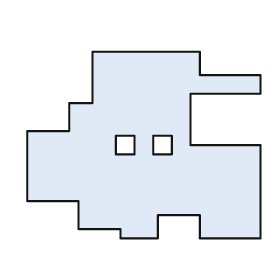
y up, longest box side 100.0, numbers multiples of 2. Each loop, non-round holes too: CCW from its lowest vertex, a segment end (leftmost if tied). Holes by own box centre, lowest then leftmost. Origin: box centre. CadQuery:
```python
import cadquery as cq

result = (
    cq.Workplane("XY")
    .moveTo(-10.0, -40.0)
    .lineTo(6.0, -40.0)
    .lineTo(6.0, -30.0)
    .lineTo(24.0, -30.0)
    .lineTo(24.0, -40.0)
    .lineTo(50.0, -40.0)
    .lineTo(50.0, 0.0)
    .lineTo(20.0, 0.0)
    .lineTo(20.0, 22.0)
    .lineTo(50.0, 22.0)
    .lineTo(50.0, 30.0)
    .lineTo(24.0, 30.0)
    .lineTo(24.0, 40.0)
    .lineTo(-22.0, 40.0)
    .lineTo(-22.0, 18.0)
    .lineTo(-32.0, 18.0)
    .lineTo(-32.0, 6.0)
    .lineTo(-50.0, 6.0)
    .lineTo(-50.0, -24.0)
    .lineTo(-28.0, -24.0)
    .lineTo(-28.0, -36.0)
    .lineTo(-10.0, -36.0)
    .close()
    .moveTo(-12.0, -4.0)
    .lineTo(-4.0, -4.0)
    .lineTo(-4.0, 4.0)
    .lineTo(-12.0, 4.0)
    .close()
    .moveTo(4.0, -4.0)
    .lineTo(12.0, -4.0)
    .lineTo(12.0, 4.0)
    .lineTo(4.0, 4.0)
    .close()
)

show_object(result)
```